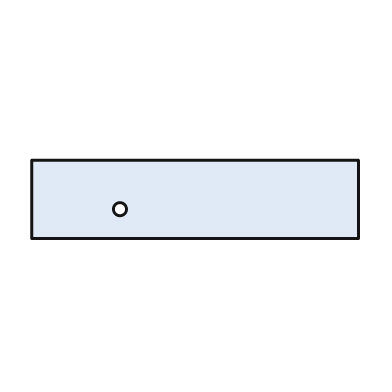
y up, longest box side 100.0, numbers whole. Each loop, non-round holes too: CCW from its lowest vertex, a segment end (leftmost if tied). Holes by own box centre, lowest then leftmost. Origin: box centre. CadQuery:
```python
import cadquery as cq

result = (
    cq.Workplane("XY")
    .moveTo(-50.0, -12.0)
    .lineTo(50.0, -12.0)
    .lineTo(50.0, 12.0)
    .lineTo(-50.0, 12.0)
    .close()
    .moveTo(-23.0, -3.0)
    .circle(2.0)
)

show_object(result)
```